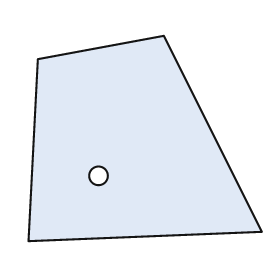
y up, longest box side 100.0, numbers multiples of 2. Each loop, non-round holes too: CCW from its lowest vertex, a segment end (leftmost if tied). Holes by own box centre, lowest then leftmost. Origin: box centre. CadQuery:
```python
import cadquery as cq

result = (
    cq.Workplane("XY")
    .moveTo(-50.0, -44.0)
    .lineTo(50.0, -40.0)
    .lineTo(8.0, 44.0)
    .lineTo(-46.0, 34.0)
    .close()
    .moveTo(-20.0, -16.0)
    .circle(4.0)
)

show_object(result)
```